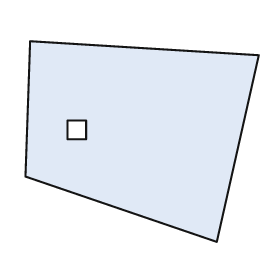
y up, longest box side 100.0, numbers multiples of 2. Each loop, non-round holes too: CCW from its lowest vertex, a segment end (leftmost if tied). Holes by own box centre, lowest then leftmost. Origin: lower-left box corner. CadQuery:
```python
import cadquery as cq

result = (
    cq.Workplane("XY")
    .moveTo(82.0, 0.0)
    .lineTo(100.0, 80.0)
    .lineTo(2.0, 86.0)
    .lineTo(0.0, 28.0)
    .close()
    .moveTo(18.0, 44.0)
    .lineTo(26.0, 44.0)
    .lineTo(26.0, 52.0)
    .lineTo(18.0, 52.0)
    .close()
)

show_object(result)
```